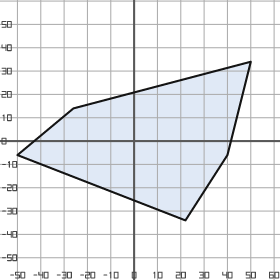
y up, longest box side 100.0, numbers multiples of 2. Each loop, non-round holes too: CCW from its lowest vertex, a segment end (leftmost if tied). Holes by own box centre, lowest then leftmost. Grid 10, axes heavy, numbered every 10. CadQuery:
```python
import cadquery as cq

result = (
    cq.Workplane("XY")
    .moveTo(22.0, -34.0)
    .lineTo(40.0, -6.0)
    .lineTo(50.0, 34.0)
    .lineTo(-26.0, 14.0)
    .lineTo(-50.0, -6.0)
    .close()
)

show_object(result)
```